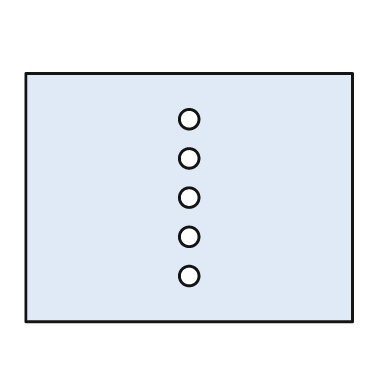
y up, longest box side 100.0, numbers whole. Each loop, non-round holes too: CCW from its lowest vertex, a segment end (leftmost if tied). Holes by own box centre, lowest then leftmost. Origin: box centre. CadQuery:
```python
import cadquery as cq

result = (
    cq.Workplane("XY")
    .moveTo(-50.0, -38.0)
    .lineTo(50.0, -38.0)
    .lineTo(50.0, 38.0)
    .lineTo(-50.0, 38.0)
    .close()
    .moveTo(0.0, -24.0)
    .circle(3.0)
    .moveTo(0.0, -12.0)
    .circle(3.0)
    .moveTo(0.0, 0.0)
    .circle(3.0)
    .moveTo(0.0, 12.0)
    .circle(3.0)
    .moveTo(0.0, 24.0)
    .circle(3.0)
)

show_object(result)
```